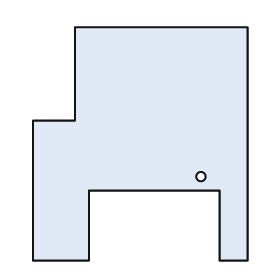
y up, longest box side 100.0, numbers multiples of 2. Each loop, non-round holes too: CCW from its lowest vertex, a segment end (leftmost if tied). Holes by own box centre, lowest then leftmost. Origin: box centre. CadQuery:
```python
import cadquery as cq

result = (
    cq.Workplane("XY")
    .moveTo(-46.0, -50.0)
    .lineTo(-22.0, -50.0)
    .lineTo(-22.0, -20.0)
    .lineTo(34.0, -20.0)
    .lineTo(34.0, -50.0)
    .lineTo(46.0, -50.0)
    .lineTo(46.0, 50.0)
    .lineTo(-28.0, 50.0)
    .lineTo(-28.0, 10.0)
    .lineTo(-46.0, 10.0)
    .close()
    .moveTo(26.0, -14.0)
    .circle(2.0)
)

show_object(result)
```